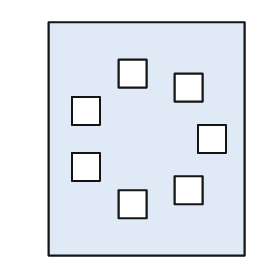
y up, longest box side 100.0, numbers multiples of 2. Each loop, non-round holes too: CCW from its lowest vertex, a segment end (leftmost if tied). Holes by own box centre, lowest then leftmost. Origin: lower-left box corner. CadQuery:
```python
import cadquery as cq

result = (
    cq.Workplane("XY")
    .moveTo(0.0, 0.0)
    .lineTo(84.0, 0.0)
    .lineTo(84.0, 100.0)
    .lineTo(0.0, 100.0)
    .close()
    .moveTo(30.0, 16.0)
    .lineTo(42.0, 16.0)
    .lineTo(42.0, 28.0)
    .lineTo(30.0, 28.0)
    .close()
    .moveTo(54.0, 22.0)
    .lineTo(66.0, 22.0)
    .lineTo(66.0, 34.0)
    .lineTo(54.0, 34.0)
    .close()
    .moveTo(10.0, 32.0)
    .lineTo(22.0, 32.0)
    .lineTo(22.0, 44.0)
    .lineTo(10.0, 44.0)
    .close()
    .moveTo(64.0, 44.0)
    .lineTo(76.0, 44.0)
    .lineTo(76.0, 56.0)
    .lineTo(64.0, 56.0)
    .close()
    .moveTo(10.0, 56.0)
    .lineTo(22.0, 56.0)
    .lineTo(22.0, 68.0)
    .lineTo(10.0, 68.0)
    .close()
    .moveTo(54.0, 66.0)
    .lineTo(66.0, 66.0)
    .lineTo(66.0, 78.0)
    .lineTo(54.0, 78.0)
    .close()
    .moveTo(30.0, 72.0)
    .lineTo(42.0, 72.0)
    .lineTo(42.0, 84.0)
    .lineTo(30.0, 84.0)
    .close()
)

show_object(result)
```